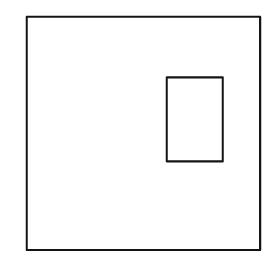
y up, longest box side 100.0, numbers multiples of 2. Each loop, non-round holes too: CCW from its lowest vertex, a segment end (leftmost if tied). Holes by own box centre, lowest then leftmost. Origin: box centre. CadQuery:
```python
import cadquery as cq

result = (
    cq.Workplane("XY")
    .moveTo(-50.0, -50.0)
    .lineTo(50.0, -50.0)
    .lineTo(50.0, 50.0)
    .lineTo(-50.0, 50.0)
    .close()
    .moveTo(10.0, -12.0)
    .lineTo(34.0, -12.0)
    .lineTo(34.0, 24.0)
    .lineTo(10.0, 24.0)
    .close()
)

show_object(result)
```